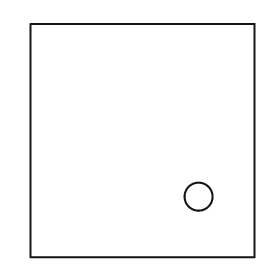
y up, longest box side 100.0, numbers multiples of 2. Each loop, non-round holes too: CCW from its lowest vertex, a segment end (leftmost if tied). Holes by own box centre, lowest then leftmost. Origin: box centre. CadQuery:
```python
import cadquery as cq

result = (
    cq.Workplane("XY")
    .moveTo(-48.0, -50.0)
    .lineTo(48.0, -50.0)
    .lineTo(48.0, 50.0)
    .lineTo(-48.0, 50.0)
    .close()
    .moveTo(24.0, -24.0)
    .circle(6.0)
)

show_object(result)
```